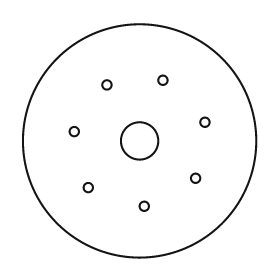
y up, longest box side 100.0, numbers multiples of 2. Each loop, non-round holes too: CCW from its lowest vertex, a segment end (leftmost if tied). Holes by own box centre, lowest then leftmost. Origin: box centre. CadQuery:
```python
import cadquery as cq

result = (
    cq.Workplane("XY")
    .moveTo(0.0, 0.0)
    .circle(50.0)
    .moveTo(2.0, -28.0)
    .circle(2.0)
    .moveTo(-22.0, -20.0)
    .circle(2.0)
    .moveTo(24.0, -16.0)
    .circle(2.0)
    .moveTo(0.0, 0.0)
    .circle(8.0)
    .moveTo(-28.0, 4.0)
    .circle(2.0)
    .moveTo(28.0, 8.0)
    .circle(2.0)
    .moveTo(-14.0, 24.0)
    .circle(2.0)
    .moveTo(10.0, 26.0)
    .circle(2.0)
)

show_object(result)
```